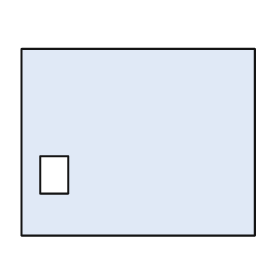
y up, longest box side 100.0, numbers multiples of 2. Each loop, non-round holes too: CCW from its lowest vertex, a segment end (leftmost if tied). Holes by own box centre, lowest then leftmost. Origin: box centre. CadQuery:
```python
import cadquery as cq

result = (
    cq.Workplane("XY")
    .moveTo(-50.0, -40.0)
    .lineTo(50.0, -40.0)
    .lineTo(50.0, 40.0)
    .lineTo(-50.0, 40.0)
    .close()
    .moveTo(-42.0, -22.0)
    .lineTo(-30.0, -22.0)
    .lineTo(-30.0, -6.0)
    .lineTo(-42.0, -6.0)
    .close()
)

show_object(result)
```